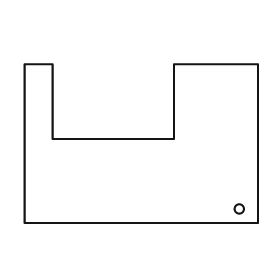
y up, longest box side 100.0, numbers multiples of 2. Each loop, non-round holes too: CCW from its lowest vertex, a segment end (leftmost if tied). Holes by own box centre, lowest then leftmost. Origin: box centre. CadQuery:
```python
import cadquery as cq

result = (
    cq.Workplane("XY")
    .moveTo(-50.0, -34.0)
    .lineTo(50.0, -34.0)
    .lineTo(50.0, 34.0)
    .lineTo(14.0, 34.0)
    .lineTo(14.0, 2.0)
    .lineTo(-38.0, 2.0)
    .lineTo(-38.0, 34.0)
    .lineTo(-50.0, 34.0)
    .close()
    .moveTo(42.0, -28.0)
    .circle(2.0)
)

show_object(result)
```